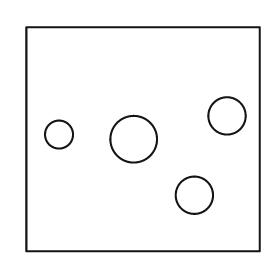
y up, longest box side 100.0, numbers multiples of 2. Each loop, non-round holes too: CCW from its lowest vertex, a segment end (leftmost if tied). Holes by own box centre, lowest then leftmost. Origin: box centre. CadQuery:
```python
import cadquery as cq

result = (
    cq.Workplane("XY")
    .moveTo(-50.0, -48.0)
    .lineTo(50.0, -48.0)
    .lineTo(50.0, 48.0)
    .lineTo(-50.0, 48.0)
    .close()
    .moveTo(22.0, -24.0)
    .circle(8.0)
    .moveTo(-4.0, 0.0)
    .circle(10.0)
    .moveTo(-36.0, 2.0)
    .circle(6.0)
    .moveTo(36.0, 10.0)
    .circle(8.0)
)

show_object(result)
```